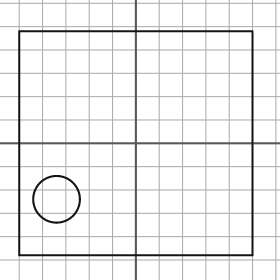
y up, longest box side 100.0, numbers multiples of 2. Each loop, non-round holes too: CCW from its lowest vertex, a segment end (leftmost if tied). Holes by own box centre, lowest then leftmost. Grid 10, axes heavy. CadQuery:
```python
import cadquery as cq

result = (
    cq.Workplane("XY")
    .moveTo(-50.0, -48.0)
    .lineTo(50.0, -48.0)
    .lineTo(50.0, 48.0)
    .lineTo(-50.0, 48.0)
    .close()
    .moveTo(-34.0, -24.0)
    .circle(10.0)
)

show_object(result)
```